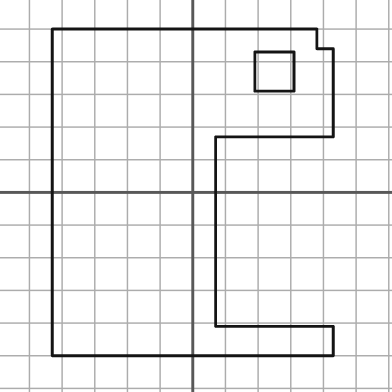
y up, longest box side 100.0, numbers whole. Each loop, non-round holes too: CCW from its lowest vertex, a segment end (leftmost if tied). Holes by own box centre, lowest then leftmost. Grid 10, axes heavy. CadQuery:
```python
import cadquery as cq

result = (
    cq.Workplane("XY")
    .moveTo(-43.0, -50.0)
    .lineTo(43.0, -50.0)
    .lineTo(43.0, -41.0)
    .lineTo(7.0, -41.0)
    .lineTo(7.0, 17.0)
    .lineTo(43.0, 17.0)
    .lineTo(43.0, 44.0)
    .lineTo(38.0, 44.0)
    .lineTo(38.0, 50.0)
    .lineTo(-43.0, 50.0)
    .close()
    .moveTo(19.0, 31.0)
    .lineTo(31.0, 31.0)
    .lineTo(31.0, 43.0)
    .lineTo(19.0, 43.0)
    .close()
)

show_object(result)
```